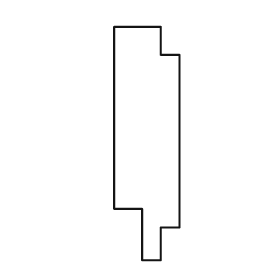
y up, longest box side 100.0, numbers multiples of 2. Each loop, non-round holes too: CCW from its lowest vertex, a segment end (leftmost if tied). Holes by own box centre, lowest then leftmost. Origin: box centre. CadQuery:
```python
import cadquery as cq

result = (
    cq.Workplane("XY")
    .moveTo(-2.0, -50.0)
    .lineTo(6.0, -50.0)
    .lineTo(6.0, -36.0)
    .lineTo(14.0, -36.0)
    .lineTo(14.0, 38.0)
    .lineTo(6.0, 38.0)
    .lineTo(6.0, 50.0)
    .lineTo(-14.0, 50.0)
    .lineTo(-14.0, -28.0)
    .lineTo(-2.0, -28.0)
    .close()
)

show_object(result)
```